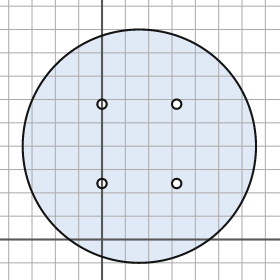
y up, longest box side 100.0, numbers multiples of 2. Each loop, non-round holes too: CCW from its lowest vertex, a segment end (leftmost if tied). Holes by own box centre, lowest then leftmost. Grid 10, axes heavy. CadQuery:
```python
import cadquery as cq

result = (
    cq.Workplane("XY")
    .moveTo(16.0, 40.0)
    .circle(50.0)
    .moveTo(0.0, 24.0)
    .circle(2.0)
    .moveTo(32.0, 24.0)
    .circle(2.0)
    .moveTo(0.0, 58.0)
    .circle(2.0)
    .moveTo(32.0, 58.0)
    .circle(2.0)
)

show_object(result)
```